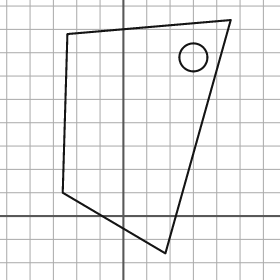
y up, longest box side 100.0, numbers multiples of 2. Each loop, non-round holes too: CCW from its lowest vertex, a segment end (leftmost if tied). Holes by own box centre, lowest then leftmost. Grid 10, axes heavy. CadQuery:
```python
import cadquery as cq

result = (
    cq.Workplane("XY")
    .moveTo(18.0, -16.0)
    .lineTo(46.0, 84.0)
    .lineTo(-24.0, 78.0)
    .lineTo(-26.0, 10.0)
    .close()
    .moveTo(30.0, 68.0)
    .circle(6.0)
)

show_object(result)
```